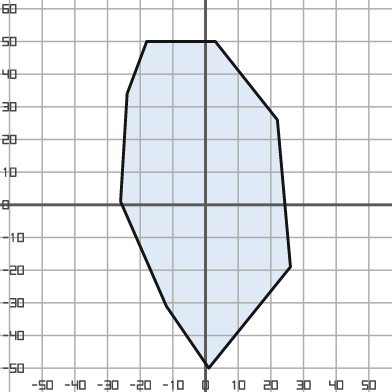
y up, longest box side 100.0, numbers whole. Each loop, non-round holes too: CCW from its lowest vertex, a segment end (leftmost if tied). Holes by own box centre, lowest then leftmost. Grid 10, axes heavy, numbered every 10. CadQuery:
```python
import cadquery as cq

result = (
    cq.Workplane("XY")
    .moveTo(1.0, -50.0)
    .lineTo(26.0, -19.0)
    .lineTo(22.0, 26.0)
    .lineTo(3.0, 50.0)
    .lineTo(-18.0, 50.0)
    .lineTo(-24.0, 34.0)
    .lineTo(-26.0, 1.0)
    .lineTo(-12.0, -31.0)
    .close()
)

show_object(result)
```